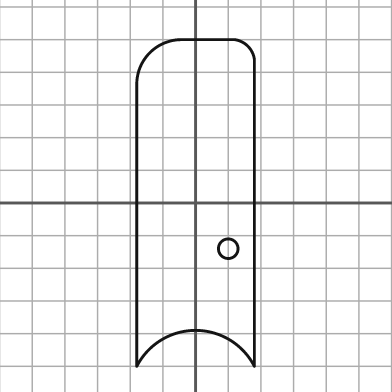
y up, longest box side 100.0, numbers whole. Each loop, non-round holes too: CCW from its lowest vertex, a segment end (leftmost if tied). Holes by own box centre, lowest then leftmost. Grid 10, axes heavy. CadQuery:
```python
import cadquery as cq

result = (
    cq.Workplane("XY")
    .moveTo(-18.0, -50.0)
    .threePointArc((0.0, -39.0), (18.0, -50.0))
    .lineTo(18.0, 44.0)
    .threePointArc((16.0, 48.0), (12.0, 50.0))
    .lineTo(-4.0, 50.0)
    .threePointArc((-14.0, 46.0), (-18.0, 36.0))
    .close()
    .moveTo(10.0, -14.0)
    .circle(3.0)
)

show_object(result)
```